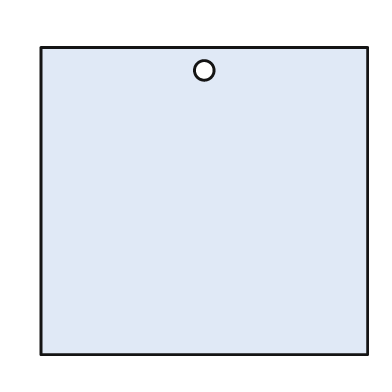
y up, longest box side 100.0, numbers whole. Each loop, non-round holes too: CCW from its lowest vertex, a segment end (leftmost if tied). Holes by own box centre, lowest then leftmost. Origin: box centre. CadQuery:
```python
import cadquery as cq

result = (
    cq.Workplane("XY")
    .moveTo(-50.0, -47.0)
    .lineTo(50.0, -47.0)
    .lineTo(50.0, 47.0)
    .lineTo(-50.0, 47.0)
    .close()
    .moveTo(0.0, 40.0)
    .circle(3.0)
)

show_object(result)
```